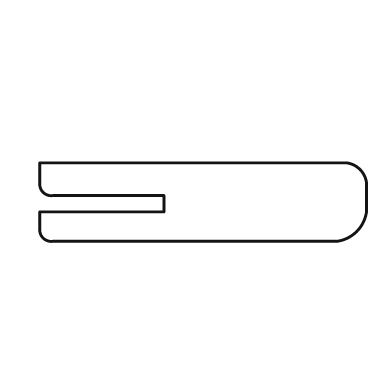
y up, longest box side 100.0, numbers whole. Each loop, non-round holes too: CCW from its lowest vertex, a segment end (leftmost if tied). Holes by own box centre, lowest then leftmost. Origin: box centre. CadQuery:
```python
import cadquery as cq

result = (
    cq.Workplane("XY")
    .moveTo(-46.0, -12.0)
    .lineTo(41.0, -12.0)
    .threePointArc((47.0, -9.0), (50.0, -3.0))
    .lineTo(50.0, 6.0)
    .threePointArc((48.0, 10.0), (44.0, 12.0))
    .lineTo(-50.0, 12.0)
    .lineTo(-50.0, 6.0)
    .threePointArc((-49.0, 3.0), (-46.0, 2.0))
    .lineTo(-12.0, 2.0)
    .lineTo(-12.0, -3.0)
    .lineTo(-50.0, -3.0)
    .lineTo(-50.0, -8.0)
    .threePointArc((-49.0, -11.0), (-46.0, -12.0))
    .close()
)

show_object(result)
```